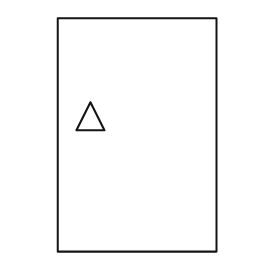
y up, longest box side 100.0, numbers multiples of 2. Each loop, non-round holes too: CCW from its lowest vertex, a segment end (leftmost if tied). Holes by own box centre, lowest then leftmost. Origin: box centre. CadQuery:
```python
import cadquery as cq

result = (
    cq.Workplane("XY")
    .moveTo(-34.0, -50.0)
    .lineTo(34.0, -50.0)
    .lineTo(34.0, 50.0)
    .lineTo(-34.0, 50.0)
    .close()
    .moveTo(-26.0, 2.0)
    .lineTo(-14.0, 2.0)
    .lineTo(-20.0, 14.0)
    .close()
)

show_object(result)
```